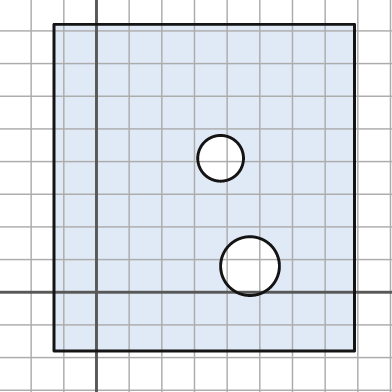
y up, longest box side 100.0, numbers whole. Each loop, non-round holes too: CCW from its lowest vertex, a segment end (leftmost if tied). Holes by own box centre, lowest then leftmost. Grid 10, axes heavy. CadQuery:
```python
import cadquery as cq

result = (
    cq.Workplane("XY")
    .moveTo(-13.0, -18.0)
    .lineTo(79.0, -18.0)
    .lineTo(79.0, 82.0)
    .lineTo(-13.0, 82.0)
    .close()
    .moveTo(47.0, 8.0)
    .circle(9.0)
    .moveTo(38.0, 41.0)
    .circle(7.0)
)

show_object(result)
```